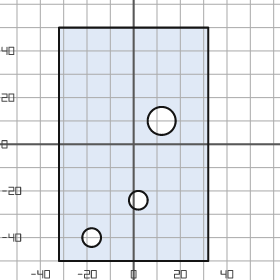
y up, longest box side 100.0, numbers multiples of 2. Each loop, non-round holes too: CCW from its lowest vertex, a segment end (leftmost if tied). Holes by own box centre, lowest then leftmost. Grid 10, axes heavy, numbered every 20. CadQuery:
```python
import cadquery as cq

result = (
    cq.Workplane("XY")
    .moveTo(-32.0, -50.0)
    .lineTo(32.0, -50.0)
    .lineTo(32.0, 50.0)
    .lineTo(-32.0, 50.0)
    .close()
    .moveTo(-18.0, -40.0)
    .circle(4.0)
    .moveTo(2.0, -24.0)
    .circle(4.0)
    .moveTo(12.0, 10.0)
    .circle(6.0)
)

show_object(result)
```